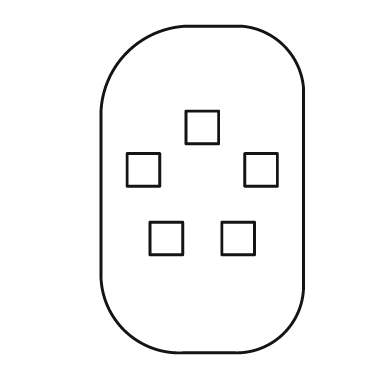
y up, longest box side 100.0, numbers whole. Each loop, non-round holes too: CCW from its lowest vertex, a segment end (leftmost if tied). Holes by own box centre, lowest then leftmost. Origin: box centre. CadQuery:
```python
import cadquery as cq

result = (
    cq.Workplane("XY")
    .moveTo(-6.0, -50.0)
    .lineTo(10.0, -50.0)
    .threePointArc((25.0, -44.0), (31.0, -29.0))
    .lineTo(31.0, 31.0)
    .threePointArc((25.0, 44.0), (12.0, 50.0))
    .lineTo(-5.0, 50.0)
    .threePointArc((-23.0, 42.0), (-31.0, 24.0))
    .lineTo(-31.0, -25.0)
    .threePointArc((-24.0, -43.0), (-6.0, -50.0))
    .close()
    .moveTo(-16.0, -20.0)
    .lineTo(-6.0, -20.0)
    .lineTo(-6.0, -10.0)
    .lineTo(-16.0, -10.0)
    .close()
    .moveTo(6.0, -20.0)
    .lineTo(16.0, -20.0)
    .lineTo(16.0, -10.0)
    .lineTo(6.0, -10.0)
    .close()
    .moveTo(-23.0, 1.0)
    .lineTo(-13.0, 1.0)
    .lineTo(-13.0, 11.0)
    .lineTo(-23.0, 11.0)
    .close()
    .moveTo(13.0, 1.0)
    .lineTo(23.0, 1.0)
    .lineTo(23.0, 11.0)
    .lineTo(13.0, 11.0)
    .close()
    .moveTo(-5.0, 14.0)
    .lineTo(5.0, 14.0)
    .lineTo(5.0, 24.0)
    .lineTo(-5.0, 24.0)
    .close()
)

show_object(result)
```